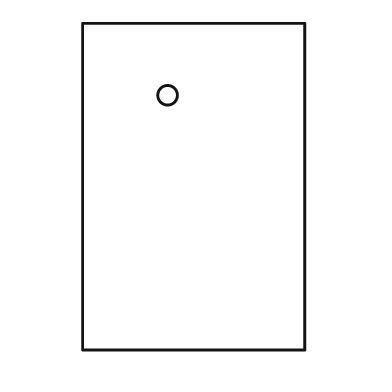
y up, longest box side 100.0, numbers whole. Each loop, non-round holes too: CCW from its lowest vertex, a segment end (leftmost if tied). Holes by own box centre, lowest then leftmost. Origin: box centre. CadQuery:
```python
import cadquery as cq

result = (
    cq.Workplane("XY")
    .moveTo(-34.0, -50.0)
    .lineTo(34.0, -50.0)
    .lineTo(34.0, 50.0)
    .lineTo(-34.0, 50.0)
    .close()
    .moveTo(-8.0, 28.0)
    .circle(3.0)
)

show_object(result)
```